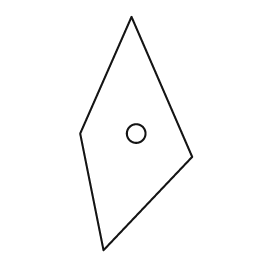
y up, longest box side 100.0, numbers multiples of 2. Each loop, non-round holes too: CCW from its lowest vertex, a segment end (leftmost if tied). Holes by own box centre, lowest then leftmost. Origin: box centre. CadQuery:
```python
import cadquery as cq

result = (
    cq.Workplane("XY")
    .moveTo(-14.0, -50.0)
    .lineTo(24.0, -10.0)
    .lineTo(-2.0, 50.0)
    .lineTo(-24.0, 0.0)
    .close()
    .moveTo(0.0, 0.0)
    .circle(4.0)
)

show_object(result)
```